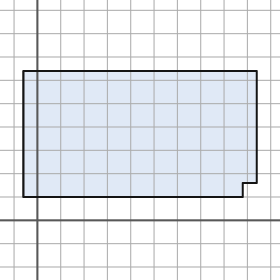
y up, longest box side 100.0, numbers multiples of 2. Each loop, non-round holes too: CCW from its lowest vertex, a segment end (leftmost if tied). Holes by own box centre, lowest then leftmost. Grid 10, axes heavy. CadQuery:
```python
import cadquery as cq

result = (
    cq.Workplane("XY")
    .moveTo(-6.0, 10.0)
    .lineTo(88.0, 10.0)
    .lineTo(88.0, 16.0)
    .lineTo(94.0, 16.0)
    .lineTo(94.0, 64.0)
    .lineTo(-6.0, 64.0)
    .close()
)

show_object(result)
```